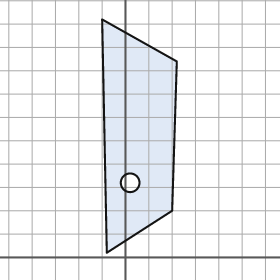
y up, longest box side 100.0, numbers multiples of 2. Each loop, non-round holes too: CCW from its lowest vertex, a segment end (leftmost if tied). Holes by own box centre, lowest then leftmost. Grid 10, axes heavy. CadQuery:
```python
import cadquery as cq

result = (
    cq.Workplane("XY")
    .moveTo(-8.0, 2.0)
    .lineTo(20.0, 20.0)
    .lineTo(22.0, 84.0)
    .lineTo(-10.0, 102.0)
    .close()
    .moveTo(2.0, 32.0)
    .circle(4.0)
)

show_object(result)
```